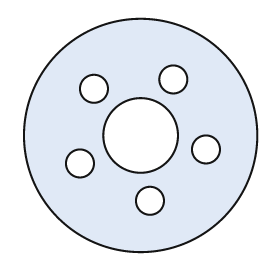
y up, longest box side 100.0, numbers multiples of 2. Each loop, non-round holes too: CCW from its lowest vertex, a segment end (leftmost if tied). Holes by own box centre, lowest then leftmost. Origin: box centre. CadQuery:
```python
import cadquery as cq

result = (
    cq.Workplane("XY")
    .moveTo(0.0, 0.0)
    .circle(50.0)
    .moveTo(4.0, -28.0)
    .circle(6.0)
    .moveTo(-26.0, -12.0)
    .circle(6.0)
    .moveTo(28.0, -6.0)
    .circle(6.0)
    .moveTo(0.0, 0.0)
    .circle(16.0)
    .moveTo(-20.0, 20.0)
    .circle(6.0)
    .moveTo(14.0, 24.0)
    .circle(6.0)
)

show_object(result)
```